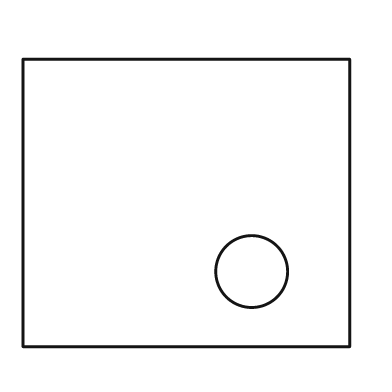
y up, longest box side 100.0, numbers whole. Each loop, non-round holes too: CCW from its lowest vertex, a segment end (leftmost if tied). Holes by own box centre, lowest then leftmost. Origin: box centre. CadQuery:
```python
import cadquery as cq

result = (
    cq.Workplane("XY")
    .moveTo(-50.0, -44.0)
    .lineTo(50.0, -44.0)
    .lineTo(50.0, 44.0)
    .lineTo(-50.0, 44.0)
    .close()
    .moveTo(20.0, -21.0)
    .circle(11.0)
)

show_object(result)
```